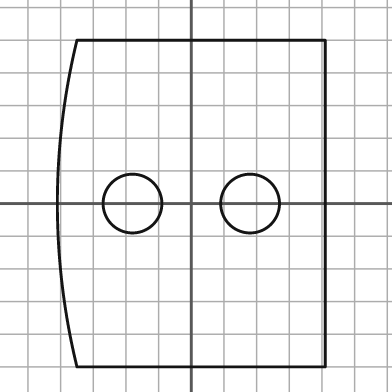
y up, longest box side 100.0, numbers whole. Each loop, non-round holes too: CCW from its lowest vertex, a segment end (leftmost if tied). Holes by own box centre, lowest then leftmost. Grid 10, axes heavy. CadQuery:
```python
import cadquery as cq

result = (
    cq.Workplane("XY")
    .moveTo(-35.0, -50.0)
    .lineTo(41.0, -50.0)
    .lineTo(41.0, 50.0)
    .lineTo(-35.0, 50.0)
    .threePointArc((-41.0, 0.0), (-35.0, -50.0))
    .close()
    .moveTo(-18.0, 0.0)
    .circle(9.0)
    .moveTo(18.0, 0.0)
    .circle(9.0)
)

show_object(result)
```